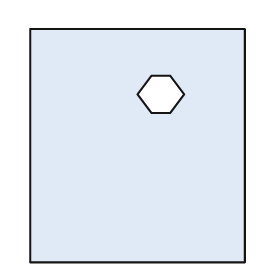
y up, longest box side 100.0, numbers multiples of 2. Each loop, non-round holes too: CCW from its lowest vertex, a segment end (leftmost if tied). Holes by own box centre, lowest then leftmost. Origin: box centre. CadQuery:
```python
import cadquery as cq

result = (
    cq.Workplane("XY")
    .moveTo(-46.0, -50.0)
    .lineTo(46.0, -50.0)
    .lineTo(46.0, 50.0)
    .lineTo(-46.0, 50.0)
    .close()
    .moveTo(6.0, 14.0)
    .lineTo(14.0, 14.0)
    .lineTo(20.0, 22.0)
    .lineTo(14.0, 30.0)
    .lineTo(6.0, 30.0)
    .lineTo(0.0, 22.0)
    .close()
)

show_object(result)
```